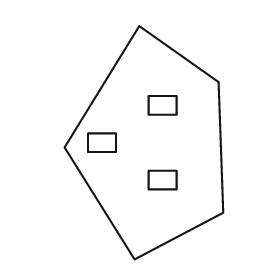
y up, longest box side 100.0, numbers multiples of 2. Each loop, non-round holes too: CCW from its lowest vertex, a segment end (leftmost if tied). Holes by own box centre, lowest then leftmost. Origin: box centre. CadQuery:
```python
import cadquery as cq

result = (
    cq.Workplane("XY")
    .moveTo(-4.0, -50.0)
    .lineTo(34.0, -30.0)
    .lineTo(32.0, 26.0)
    .lineTo(-2.0, 50.0)
    .lineTo(-34.0, -2.0)
    .close()
    .moveTo(2.0, -20.0)
    .lineTo(14.0, -20.0)
    .lineTo(14.0, -12.0)
    .lineTo(2.0, -12.0)
    .close()
    .moveTo(-24.0, -4.0)
    .lineTo(-12.0, -4.0)
    .lineTo(-12.0, 4.0)
    .lineTo(-24.0, 4.0)
    .close()
    .moveTo(2.0, 12.0)
    .lineTo(14.0, 12.0)
    .lineTo(14.0, 20.0)
    .lineTo(2.0, 20.0)
    .close()
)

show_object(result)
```